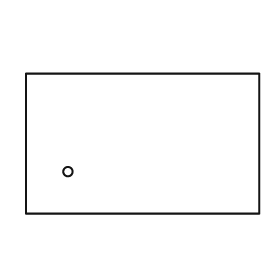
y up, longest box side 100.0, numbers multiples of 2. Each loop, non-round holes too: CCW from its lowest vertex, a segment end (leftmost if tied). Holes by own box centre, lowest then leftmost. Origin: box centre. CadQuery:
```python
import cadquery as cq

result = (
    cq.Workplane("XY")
    .moveTo(-50.0, -30.0)
    .lineTo(50.0, -30.0)
    .lineTo(50.0, 30.0)
    .lineTo(-50.0, 30.0)
    .close()
    .moveTo(-32.0, -12.0)
    .circle(2.0)
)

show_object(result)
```